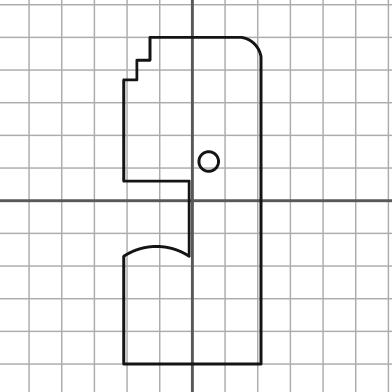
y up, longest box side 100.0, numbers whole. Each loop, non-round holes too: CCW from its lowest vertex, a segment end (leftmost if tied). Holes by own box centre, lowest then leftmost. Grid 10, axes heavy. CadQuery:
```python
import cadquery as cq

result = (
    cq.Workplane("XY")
    .moveTo(-21.0, -50.0)
    .lineTo(21.0, -50.0)
    .lineTo(21.0, 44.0)
    .threePointArc((19.0, 48.0), (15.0, 50.0))
    .lineTo(-13.0, 50.0)
    .lineTo(-13.0, 43.0)
    .lineTo(-17.0, 43.0)
    .lineTo(-17.0, 37.0)
    .lineTo(-21.0, 37.0)
    .lineTo(-21.0, 6.0)
    .lineTo(-1.0, 6.0)
    .lineTo(-1.0, -17.0)
    .threePointArc((-11.0, -14.0), (-21.0, -17.0))
    .close()
    .moveTo(5.0, 12.0)
    .circle(3.0)
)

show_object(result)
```